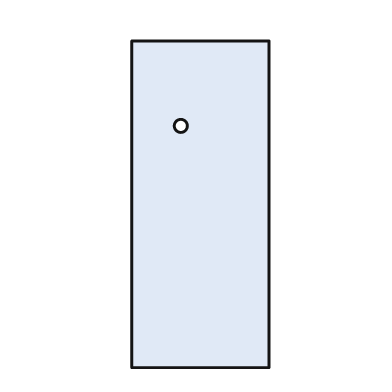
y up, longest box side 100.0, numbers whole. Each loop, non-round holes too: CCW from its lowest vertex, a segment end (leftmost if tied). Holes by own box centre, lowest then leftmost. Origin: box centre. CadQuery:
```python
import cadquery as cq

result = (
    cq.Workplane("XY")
    .moveTo(-21.0, -50.0)
    .lineTo(21.0, -50.0)
    .lineTo(21.0, 50.0)
    .lineTo(-21.0, 50.0)
    .close()
    .moveTo(-6.0, 24.0)
    .circle(2.0)
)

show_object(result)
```